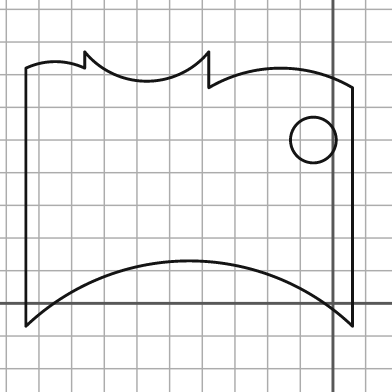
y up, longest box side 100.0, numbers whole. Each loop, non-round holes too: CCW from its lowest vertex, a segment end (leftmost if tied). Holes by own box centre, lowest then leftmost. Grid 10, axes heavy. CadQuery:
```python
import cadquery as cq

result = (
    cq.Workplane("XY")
    .moveTo(-94.0, -7.0)
    .threePointArc((-44.0, 13.0), (6.0, -7.0))
    .lineTo(6.0, 66.0)
    .threePointArc((-16.0, 72.0), (-38.0, 66.0))
    .lineTo(-38.0, 77.0)
    .threePointArc((-57.0, 68.0), (-76.0, 77.0))
    .lineTo(-76.0, 72.0)
    .threePointArc((-85.0, 74.0), (-94.0, 72.0))
    .close()
    .moveTo(-6.0, 50.0)
    .circle(7.0)
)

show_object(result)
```